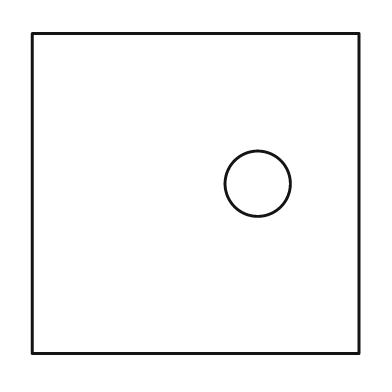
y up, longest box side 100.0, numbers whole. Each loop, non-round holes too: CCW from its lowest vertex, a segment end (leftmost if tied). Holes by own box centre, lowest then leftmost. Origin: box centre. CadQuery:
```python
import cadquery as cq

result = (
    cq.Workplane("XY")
    .moveTo(-50.0, -49.0)
    .lineTo(50.0, -49.0)
    .lineTo(50.0, 49.0)
    .lineTo(-50.0, 49.0)
    .close()
    .moveTo(19.0, 3.0)
    .circle(10.0)
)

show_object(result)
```